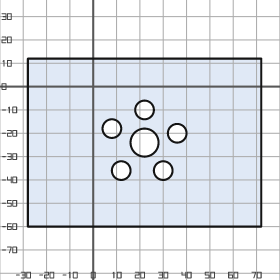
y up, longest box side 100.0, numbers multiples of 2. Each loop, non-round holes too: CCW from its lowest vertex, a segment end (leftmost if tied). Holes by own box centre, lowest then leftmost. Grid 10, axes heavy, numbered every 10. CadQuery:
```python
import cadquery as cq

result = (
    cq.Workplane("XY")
    .moveTo(-28.0, -60.0)
    .lineTo(72.0, -60.0)
    .lineTo(72.0, 12.0)
    .lineTo(-28.0, 12.0)
    .close()
    .moveTo(12.0, -36.0)
    .circle(4.0)
    .moveTo(30.0, -36.0)
    .circle(4.0)
    .moveTo(22.0, -24.0)
    .circle(6.0)
    .moveTo(36.0, -20.0)
    .circle(4.0)
    .moveTo(8.0, -18.0)
    .circle(4.0)
    .moveTo(22.0, -10.0)
    .circle(4.0)
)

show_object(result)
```